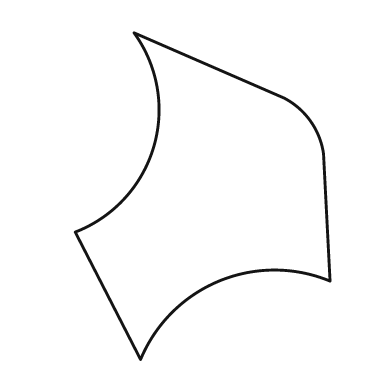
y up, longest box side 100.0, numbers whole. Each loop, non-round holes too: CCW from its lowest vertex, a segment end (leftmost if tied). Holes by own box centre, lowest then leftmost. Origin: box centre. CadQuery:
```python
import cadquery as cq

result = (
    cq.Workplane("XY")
    .moveTo(-19.0, -50.0)
    .threePointArc((5.0, -26.0), (39.0, -26.0))
    .lineTo(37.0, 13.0)
    .threePointArc((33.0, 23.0), (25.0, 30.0))
    .lineTo(-21.0, 50.0)
    .threePointArc((-15.0, 15.0), (-39.0, -11.0))
    .close()
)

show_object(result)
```